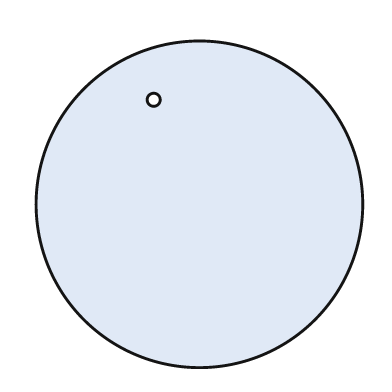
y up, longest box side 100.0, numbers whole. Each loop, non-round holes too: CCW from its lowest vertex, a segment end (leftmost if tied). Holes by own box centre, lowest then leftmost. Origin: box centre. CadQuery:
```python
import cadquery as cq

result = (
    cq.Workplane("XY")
    .moveTo(0.0, 0.0)
    .circle(50.0)
    .moveTo(-14.0, 32.0)
    .circle(2.0)
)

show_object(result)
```